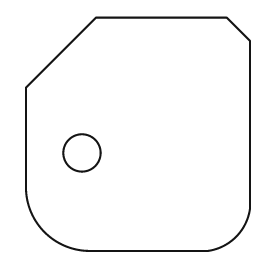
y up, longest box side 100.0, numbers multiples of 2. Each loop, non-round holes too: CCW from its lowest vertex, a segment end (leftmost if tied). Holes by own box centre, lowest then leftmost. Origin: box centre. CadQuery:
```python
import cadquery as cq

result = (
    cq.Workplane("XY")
    .moveTo(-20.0, -50.0)
    .lineTo(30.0, -50.0)
    .threePointArc((42.0, -44.0), (48.0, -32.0))
    .lineTo(48.0, 40.0)
    .lineTo(38.0, 50.0)
    .lineTo(-18.0, 50.0)
    .lineTo(-48.0, 20.0)
    .lineTo(-48.0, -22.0)
    .threePointArc((-40.0, -42.0), (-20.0, -50.0))
    .close()
    .moveTo(-24.0, -8.0)
    .circle(8.0)
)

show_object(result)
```